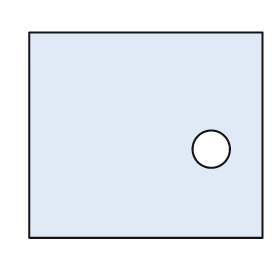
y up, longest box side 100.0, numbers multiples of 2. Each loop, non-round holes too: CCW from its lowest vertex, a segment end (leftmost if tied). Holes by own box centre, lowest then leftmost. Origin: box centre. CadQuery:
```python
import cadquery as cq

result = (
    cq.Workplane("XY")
    .moveTo(-50.0, -44.0)
    .lineTo(50.0, -44.0)
    .lineTo(50.0, 44.0)
    .lineTo(-50.0, 44.0)
    .close()
    .moveTo(28.0, -6.0)
    .circle(8.0)
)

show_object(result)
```